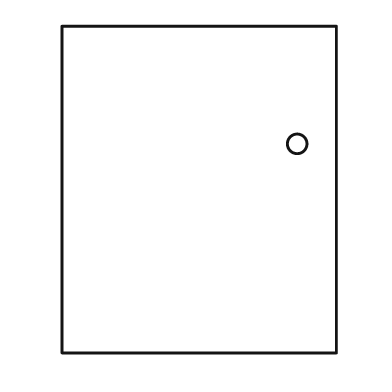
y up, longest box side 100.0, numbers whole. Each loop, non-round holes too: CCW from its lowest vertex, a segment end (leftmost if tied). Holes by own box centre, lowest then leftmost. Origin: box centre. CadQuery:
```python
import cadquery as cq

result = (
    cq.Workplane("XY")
    .moveTo(-42.0, -50.0)
    .lineTo(42.0, -50.0)
    .lineTo(42.0, 50.0)
    .lineTo(-42.0, 50.0)
    .close()
    .moveTo(30.0, 14.0)
    .circle(3.0)
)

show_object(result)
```